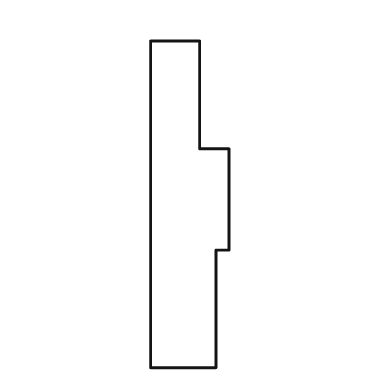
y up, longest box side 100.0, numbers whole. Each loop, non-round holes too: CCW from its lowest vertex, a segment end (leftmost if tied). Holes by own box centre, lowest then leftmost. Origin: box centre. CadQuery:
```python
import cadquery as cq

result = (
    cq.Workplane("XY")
    .moveTo(-12.0, -50.0)
    .lineTo(8.0, -50.0)
    .lineTo(8.0, -14.0)
    .lineTo(12.0, -14.0)
    .lineTo(12.0, 17.0)
    .lineTo(3.0, 17.0)
    .lineTo(3.0, 50.0)
    .lineTo(-12.0, 50.0)
    .close()
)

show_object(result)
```